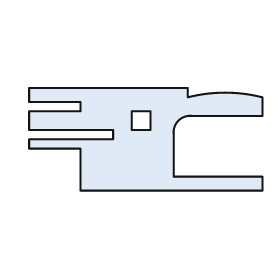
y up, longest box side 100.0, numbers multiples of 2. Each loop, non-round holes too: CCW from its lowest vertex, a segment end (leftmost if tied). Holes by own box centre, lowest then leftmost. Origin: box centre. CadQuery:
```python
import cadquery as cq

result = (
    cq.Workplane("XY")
    .moveTo(-28.0, -22.0)
    .lineTo(50.0, -22.0)
    .lineTo(50.0, -16.0)
    .lineTo(12.0, -16.0)
    .lineTo(12.0, 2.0)
    .threePointArc((14.0, 8.0), (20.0, 10.0))
    .lineTo(50.0, 10.0)
    .lineTo(50.0, 18.0)
    .threePointArc((34.0, 20.0), (18.0, 18.0))
    .lineTo(18.0, 22.0)
    .lineTo(-50.0, 22.0)
    .lineTo(-50.0, 16.0)
    .lineTo(-28.0, 16.0)
    .lineTo(-28.0, 12.0)
    .lineTo(-50.0, 12.0)
    .lineTo(-50.0, 4.0)
    .lineTo(-14.0, 4.0)
    .lineTo(-14.0, 0.0)
    .lineTo(-50.0, 0.0)
    .lineTo(-50.0, -4.0)
    .lineTo(-28.0, -4.0)
    .close()
    .moveTo(-6.0, 4.0)
    .lineTo(2.0, 4.0)
    .lineTo(2.0, 12.0)
    .lineTo(-6.0, 12.0)
    .close()
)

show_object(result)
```